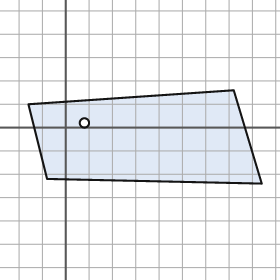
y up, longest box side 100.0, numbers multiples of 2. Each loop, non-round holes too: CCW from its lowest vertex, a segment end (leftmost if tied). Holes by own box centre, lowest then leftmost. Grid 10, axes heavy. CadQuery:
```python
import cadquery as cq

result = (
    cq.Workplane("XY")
    .moveTo(84.0, -24.0)
    .lineTo(72.0, 16.0)
    .lineTo(-16.0, 10.0)
    .lineTo(-8.0, -22.0)
    .close()
    .moveTo(8.0, 2.0)
    .circle(2.0)
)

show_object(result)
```